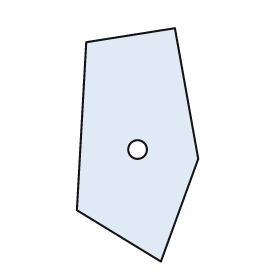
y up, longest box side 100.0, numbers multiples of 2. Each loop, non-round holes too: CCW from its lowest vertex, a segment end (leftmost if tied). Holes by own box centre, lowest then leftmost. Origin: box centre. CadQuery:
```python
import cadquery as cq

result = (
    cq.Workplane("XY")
    .moveTo(10.0, -50.0)
    .lineTo(26.0, -6.0)
    .lineTo(16.0, 50.0)
    .lineTo(-22.0, 44.0)
    .lineTo(-26.0, -28.0)
    .close()
    .moveTo(0.0, -2.0)
    .circle(4.0)
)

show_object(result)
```